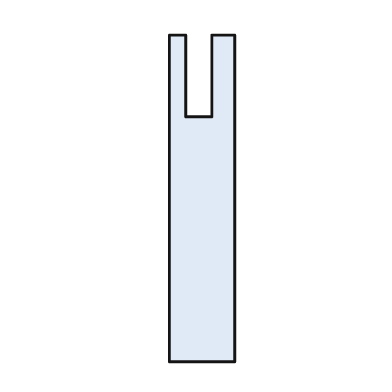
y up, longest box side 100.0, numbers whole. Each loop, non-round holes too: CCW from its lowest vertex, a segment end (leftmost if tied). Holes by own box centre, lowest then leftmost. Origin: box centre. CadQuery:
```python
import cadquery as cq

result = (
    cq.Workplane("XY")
    .moveTo(-10.0, -50.0)
    .lineTo(10.0, -50.0)
    .lineTo(10.0, 50.0)
    .lineTo(3.0, 50.0)
    .lineTo(3.0, 25.0)
    .lineTo(-5.0, 25.0)
    .lineTo(-5.0, 50.0)
    .lineTo(-10.0, 50.0)
    .close()
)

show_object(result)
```